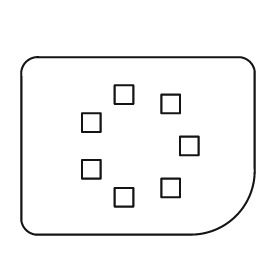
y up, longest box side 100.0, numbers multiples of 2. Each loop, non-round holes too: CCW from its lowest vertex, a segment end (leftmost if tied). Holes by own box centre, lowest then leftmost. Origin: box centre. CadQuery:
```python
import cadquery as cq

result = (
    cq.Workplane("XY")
    .moveTo(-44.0, -38.0)
    .lineTo(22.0, -38.0)
    .threePointArc((42.0, -30.0), (50.0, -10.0))
    .lineTo(50.0, 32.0)
    .threePointArc((48.0, 36.0), (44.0, 38.0))
    .lineTo(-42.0, 38.0)
    .threePointArc((-48.0, 36.0), (-50.0, 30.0))
    .lineTo(-50.0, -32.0)
    .threePointArc((-48.0, -36.0), (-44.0, -38.0))
    .close()
    .moveTo(-10.0, -26.0)
    .lineTo(-2.0, -26.0)
    .lineTo(-2.0, -18.0)
    .lineTo(-10.0, -18.0)
    .close()
    .moveTo(10.0, -22.0)
    .lineTo(18.0, -22.0)
    .lineTo(18.0, -14.0)
    .lineTo(10.0, -14.0)
    .close()
    .moveTo(-24.0, -14.0)
    .lineTo(-16.0, -14.0)
    .lineTo(-16.0, -6.0)
    .lineTo(-24.0, -6.0)
    .close()
    .moveTo(18.0, -4.0)
    .lineTo(26.0, -4.0)
    .lineTo(26.0, 4.0)
    .lineTo(18.0, 4.0)
    .close()
    .moveTo(-24.0, 6.0)
    .lineTo(-16.0, 6.0)
    .lineTo(-16.0, 14.0)
    .lineTo(-24.0, 14.0)
    .close()
    .moveTo(10.0, 14.0)
    .lineTo(18.0, 14.0)
    .lineTo(18.0, 22.0)
    .lineTo(10.0, 22.0)
    .close()
    .moveTo(-10.0, 18.0)
    .lineTo(-2.0, 18.0)
    .lineTo(-2.0, 26.0)
    .lineTo(-10.0, 26.0)
    .close()
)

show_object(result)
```